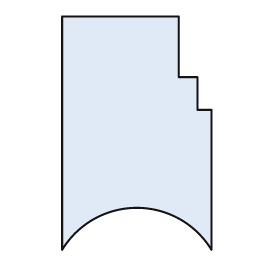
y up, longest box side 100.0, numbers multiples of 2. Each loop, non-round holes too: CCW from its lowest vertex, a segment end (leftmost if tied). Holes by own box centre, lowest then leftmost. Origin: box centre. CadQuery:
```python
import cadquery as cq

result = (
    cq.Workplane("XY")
    .moveTo(-32.0, -50.0)
    .threePointArc((0.0, -32.0), (32.0, -50.0))
    .lineTo(32.0, 10.0)
    .lineTo(26.0, 10.0)
    .lineTo(26.0, 24.0)
    .lineTo(18.0, 24.0)
    .lineTo(18.0, 50.0)
    .lineTo(-32.0, 50.0)
    .close()
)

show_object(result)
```